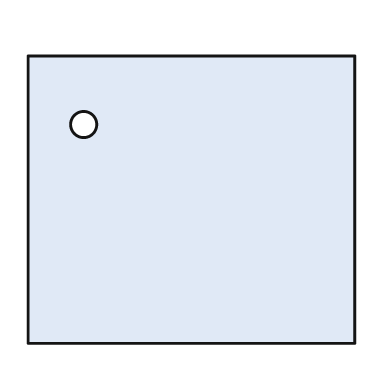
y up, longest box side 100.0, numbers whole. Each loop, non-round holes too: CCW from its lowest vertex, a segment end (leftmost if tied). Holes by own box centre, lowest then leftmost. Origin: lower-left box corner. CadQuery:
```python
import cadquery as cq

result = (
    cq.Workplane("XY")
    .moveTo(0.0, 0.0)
    .lineTo(100.0, 0.0)
    .lineTo(100.0, 88.0)
    .lineTo(0.0, 88.0)
    .close()
    .moveTo(17.0, 67.0)
    .circle(4.0)
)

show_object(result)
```